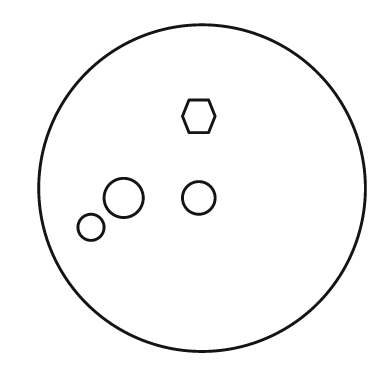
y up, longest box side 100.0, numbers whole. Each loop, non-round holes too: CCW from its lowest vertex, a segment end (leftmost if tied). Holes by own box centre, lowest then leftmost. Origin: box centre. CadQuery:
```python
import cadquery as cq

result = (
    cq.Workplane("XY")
    .moveTo(0.0, 0.0)
    .circle(50.0)
    .moveTo(-34.0, -12.0)
    .circle(4.0)
    .moveTo(-24.0, -3.0)
    .circle(6.0)
    .moveTo(-1.0, -3.0)
    .circle(5.0)
    .moveTo(-4.0, 17.0)
    .lineTo(2.0, 17.0)
    .lineTo(4.0, 22.0)
    .lineTo(2.0, 27.0)
    .lineTo(-4.0, 27.0)
    .lineTo(-6.0, 22.0)
    .close()
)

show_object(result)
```